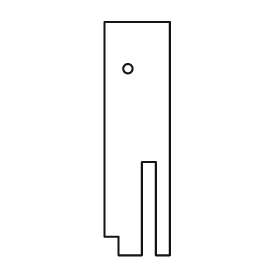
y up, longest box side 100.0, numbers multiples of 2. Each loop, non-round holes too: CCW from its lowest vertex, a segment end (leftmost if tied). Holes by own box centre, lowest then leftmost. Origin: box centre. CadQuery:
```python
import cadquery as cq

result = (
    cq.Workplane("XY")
    .moveTo(-8.0, -50.0)
    .lineTo(2.0, -50.0)
    .lineTo(2.0, -10.0)
    .lineTo(8.0, -10.0)
    .lineTo(8.0, -50.0)
    .lineTo(14.0, -50.0)
    .lineTo(14.0, 50.0)
    .lineTo(-14.0, 50.0)
    .lineTo(-14.0, -42.0)
    .lineTo(-8.0, -42.0)
    .close()
    .moveTo(-4.0, 30.0)
    .circle(2.0)
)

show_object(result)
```